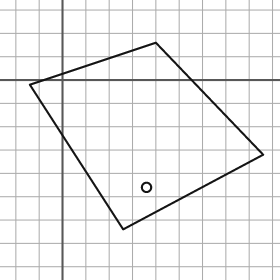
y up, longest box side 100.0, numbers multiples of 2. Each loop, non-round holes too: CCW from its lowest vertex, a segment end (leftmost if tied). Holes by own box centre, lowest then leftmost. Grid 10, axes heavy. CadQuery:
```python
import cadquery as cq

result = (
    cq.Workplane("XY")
    .moveTo(26.0, -64.0)
    .lineTo(86.0, -32.0)
    .lineTo(40.0, 16.0)
    .lineTo(-14.0, -2.0)
    .close()
    .moveTo(36.0, -46.0)
    .circle(2.0)
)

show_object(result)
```